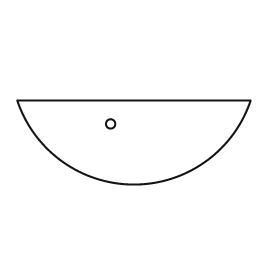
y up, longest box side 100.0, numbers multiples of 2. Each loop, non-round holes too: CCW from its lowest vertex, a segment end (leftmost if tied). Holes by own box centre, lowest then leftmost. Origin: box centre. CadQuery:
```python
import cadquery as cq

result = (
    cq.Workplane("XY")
    .moveTo(-50.0, 18.0)
    .threePointArc((0.0, -18.0), (50.0, 18.0))
    .close()
    .moveTo(-10.0, 8.0)
    .circle(2.0)
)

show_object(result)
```